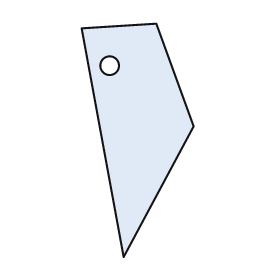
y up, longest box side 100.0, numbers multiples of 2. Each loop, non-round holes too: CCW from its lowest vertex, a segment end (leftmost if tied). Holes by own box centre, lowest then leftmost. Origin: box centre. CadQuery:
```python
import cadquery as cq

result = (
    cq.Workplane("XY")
    .moveTo(-6.0, -50.0)
    .lineTo(24.0, 6.0)
    .lineTo(8.0, 50.0)
    .lineTo(-24.0, 48.0)
    .close()
    .moveTo(-12.0, 32.0)
    .circle(4.0)
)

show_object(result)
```